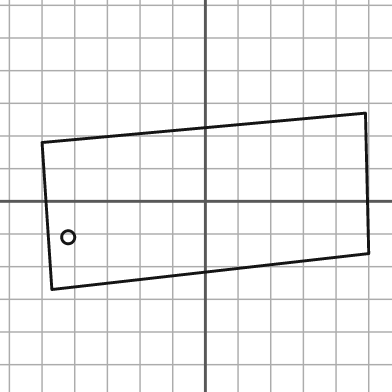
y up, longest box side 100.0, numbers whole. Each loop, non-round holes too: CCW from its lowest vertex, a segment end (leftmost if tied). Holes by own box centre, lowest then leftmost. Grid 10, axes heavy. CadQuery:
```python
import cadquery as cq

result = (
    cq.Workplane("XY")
    .moveTo(-47.0, -27.0)
    .lineTo(50.0, -16.0)
    .lineTo(49.0, 27.0)
    .lineTo(-50.0, 18.0)
    .close()
    .moveTo(-42.0, -11.0)
    .circle(2.0)
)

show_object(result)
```